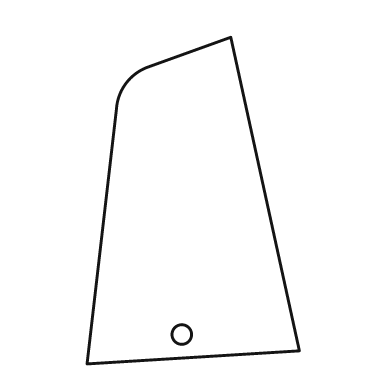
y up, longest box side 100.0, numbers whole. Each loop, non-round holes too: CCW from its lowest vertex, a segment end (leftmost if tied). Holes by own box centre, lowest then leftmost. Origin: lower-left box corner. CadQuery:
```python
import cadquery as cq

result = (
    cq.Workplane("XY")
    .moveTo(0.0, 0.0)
    .lineTo(65.0, 4.0)
    .lineTo(44.0, 100.0)
    .lineTo(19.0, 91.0)
    .threePointArc((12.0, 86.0), (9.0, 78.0))
    .close()
    .moveTo(29.0, 9.0)
    .circle(3.0)
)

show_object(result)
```